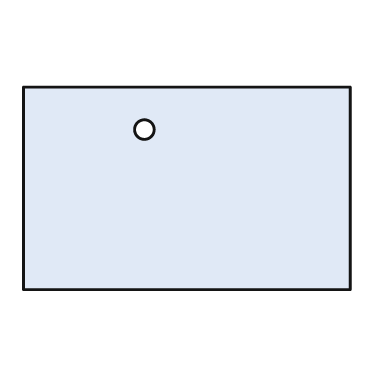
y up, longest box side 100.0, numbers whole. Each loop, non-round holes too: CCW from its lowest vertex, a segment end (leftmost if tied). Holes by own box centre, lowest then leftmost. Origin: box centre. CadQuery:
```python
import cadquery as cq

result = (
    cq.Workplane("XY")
    .moveTo(-50.0, -31.0)
    .lineTo(50.0, -31.0)
    .lineTo(50.0, 31.0)
    .lineTo(-50.0, 31.0)
    .close()
    .moveTo(-13.0, 18.0)
    .circle(3.0)
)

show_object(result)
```